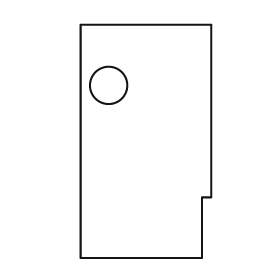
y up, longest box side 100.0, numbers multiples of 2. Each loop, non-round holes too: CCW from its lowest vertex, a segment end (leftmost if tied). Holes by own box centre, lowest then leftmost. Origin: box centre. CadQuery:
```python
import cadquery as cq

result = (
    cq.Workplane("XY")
    .moveTo(-28.0, -50.0)
    .lineTo(24.0, -50.0)
    .lineTo(24.0, -24.0)
    .lineTo(28.0, -24.0)
    .lineTo(28.0, 50.0)
    .lineTo(-28.0, 50.0)
    .close()
    .moveTo(-16.0, 24.0)
    .circle(8.0)
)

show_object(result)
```